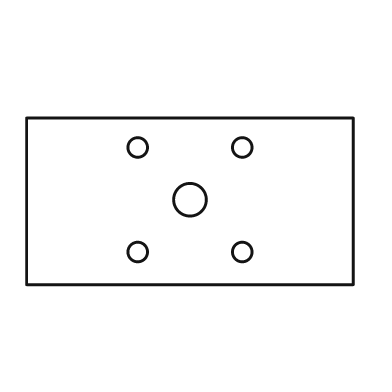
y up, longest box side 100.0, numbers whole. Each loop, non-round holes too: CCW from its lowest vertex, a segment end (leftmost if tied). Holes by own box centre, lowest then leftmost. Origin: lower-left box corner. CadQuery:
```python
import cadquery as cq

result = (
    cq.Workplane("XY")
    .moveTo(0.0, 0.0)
    .lineTo(100.0, 0.0)
    .lineTo(100.0, 51.0)
    .lineTo(0.0, 51.0)
    .close()
    .moveTo(34.0, 10.0)
    .circle(3.0)
    .moveTo(66.0, 10.0)
    .circle(3.0)
    .moveTo(50.0, 26.0)
    .circle(5.0)
    .moveTo(34.0, 42.0)
    .circle(3.0)
    .moveTo(66.0, 42.0)
    .circle(3.0)
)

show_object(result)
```